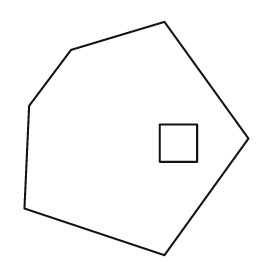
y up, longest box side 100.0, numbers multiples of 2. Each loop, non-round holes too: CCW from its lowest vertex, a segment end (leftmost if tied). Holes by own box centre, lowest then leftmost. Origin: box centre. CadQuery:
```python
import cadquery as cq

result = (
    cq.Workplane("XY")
    .moveTo(12.0, -50.0)
    .lineTo(48.0, 0.0)
    .lineTo(12.0, 50.0)
    .lineTo(-28.0, 38.0)
    .lineTo(-46.0, 14.0)
    .lineTo(-48.0, -30.0)
    .close()
    .moveTo(10.0, -10.0)
    .lineTo(26.0, -10.0)
    .lineTo(26.0, 6.0)
    .lineTo(10.0, 6.0)
    .close()
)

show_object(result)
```